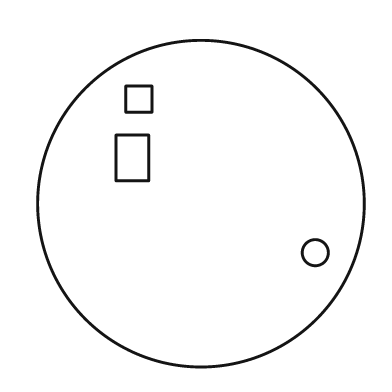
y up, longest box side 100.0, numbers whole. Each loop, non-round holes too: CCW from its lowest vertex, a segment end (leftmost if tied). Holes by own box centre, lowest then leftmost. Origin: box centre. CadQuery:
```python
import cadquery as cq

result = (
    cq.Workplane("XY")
    .moveTo(0.0, 0.0)
    .circle(50.0)
    .moveTo(35.0, -15.0)
    .circle(4.0)
    .moveTo(-26.0, 7.0)
    .lineTo(-16.0, 7.0)
    .lineTo(-16.0, 21.0)
    .lineTo(-26.0, 21.0)
    .close()
    .moveTo(-23.0, 28.0)
    .lineTo(-15.0, 28.0)
    .lineTo(-15.0, 36.0)
    .lineTo(-23.0, 36.0)
    .close()
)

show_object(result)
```